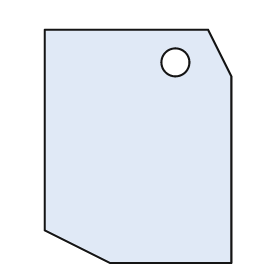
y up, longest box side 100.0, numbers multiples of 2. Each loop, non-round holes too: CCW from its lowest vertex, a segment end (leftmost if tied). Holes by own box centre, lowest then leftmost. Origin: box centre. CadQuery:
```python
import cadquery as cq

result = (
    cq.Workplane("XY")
    .moveTo(-12.0, -50.0)
    .lineTo(40.0, -50.0)
    .lineTo(40.0, 30.0)
    .lineTo(30.0, 50.0)
    .lineTo(-40.0, 50.0)
    .lineTo(-40.0, -36.0)
    .close()
    .moveTo(16.0, 36.0)
    .circle(6.0)
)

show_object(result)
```